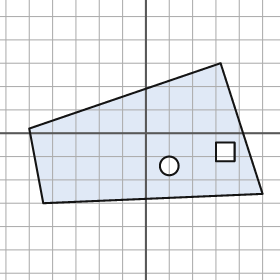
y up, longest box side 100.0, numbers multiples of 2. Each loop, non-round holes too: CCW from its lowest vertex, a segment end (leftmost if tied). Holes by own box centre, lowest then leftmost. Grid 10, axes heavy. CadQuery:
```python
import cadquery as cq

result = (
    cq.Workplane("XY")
    .moveTo(-44.0, -30.0)
    .lineTo(50.0, -26.0)
    .lineTo(32.0, 30.0)
    .lineTo(-50.0, 2.0)
    .close()
    .moveTo(10.0, -14.0)
    .circle(4.0)
    .moveTo(30.0, -12.0)
    .lineTo(38.0, -12.0)
    .lineTo(38.0, -4.0)
    .lineTo(30.0, -4.0)
    .close()
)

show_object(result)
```